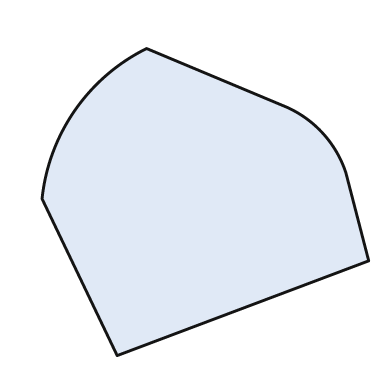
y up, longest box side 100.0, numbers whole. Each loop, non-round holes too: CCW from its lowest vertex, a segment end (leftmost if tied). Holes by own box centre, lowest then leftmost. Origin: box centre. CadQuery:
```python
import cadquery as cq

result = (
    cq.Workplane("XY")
    .moveTo(-27.0, -47.0)
    .lineTo(50.0, -18.0)
    .lineTo(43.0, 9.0)
    .threePointArc((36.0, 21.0), (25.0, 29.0))
    .lineTo(-18.0, 47.0)
    .threePointArc((-40.0, 28.0), (-50.0, 1.0))
    .close()
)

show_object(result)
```